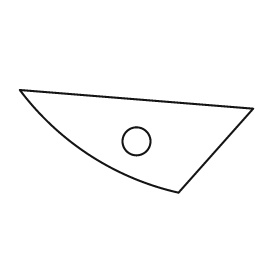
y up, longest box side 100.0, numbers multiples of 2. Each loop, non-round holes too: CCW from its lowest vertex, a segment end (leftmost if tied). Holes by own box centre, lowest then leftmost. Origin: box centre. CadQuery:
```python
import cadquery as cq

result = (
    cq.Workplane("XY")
    .moveTo(18.0, -22.0)
    .lineTo(50.0, 14.0)
    .lineTo(-50.0, 22.0)
    .threePointArc((-20.0, -6.0), (18.0, -22.0))
    .close()
    .moveTo(0.0, 0.0)
    .circle(6.0)
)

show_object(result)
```